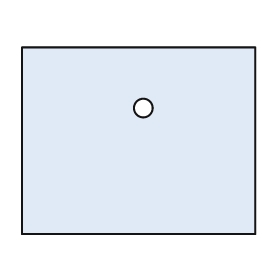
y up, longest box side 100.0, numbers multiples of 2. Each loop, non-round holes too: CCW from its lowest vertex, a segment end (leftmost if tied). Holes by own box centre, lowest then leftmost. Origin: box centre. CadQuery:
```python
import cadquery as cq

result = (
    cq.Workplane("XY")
    .moveTo(-50.0, -40.0)
    .lineTo(50.0, -40.0)
    .lineTo(50.0, 40.0)
    .lineTo(-50.0, 40.0)
    .close()
    .moveTo(2.0, 14.0)
    .circle(4.0)
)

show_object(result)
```